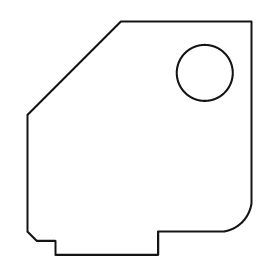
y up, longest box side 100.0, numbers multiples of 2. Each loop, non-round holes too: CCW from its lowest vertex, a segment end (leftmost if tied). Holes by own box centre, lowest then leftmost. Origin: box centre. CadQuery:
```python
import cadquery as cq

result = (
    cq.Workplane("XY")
    .moveTo(-36.0, -50.0)
    .lineTo(8.0, -50.0)
    .lineTo(8.0, -40.0)
    .lineTo(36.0, -40.0)
    .threePointArc((44.0, -36.0), (48.0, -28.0))
    .lineTo(48.0, 50.0)
    .lineTo(-8.0, 50.0)
    .lineTo(-48.0, 10.0)
    .lineTo(-48.0, -40.0)
    .lineTo(-44.0, -44.0)
    .lineTo(-36.0, -44.0)
    .close()
    .moveTo(28.0, 28.0)
    .circle(12.0)
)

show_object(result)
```